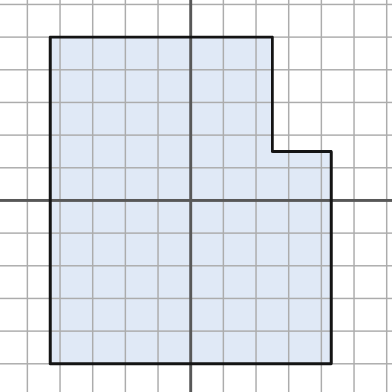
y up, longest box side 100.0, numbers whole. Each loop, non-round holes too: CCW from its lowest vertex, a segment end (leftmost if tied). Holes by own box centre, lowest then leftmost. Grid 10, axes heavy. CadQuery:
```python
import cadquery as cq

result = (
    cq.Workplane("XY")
    .moveTo(-43.0, -50.0)
    .lineTo(43.0, -50.0)
    .lineTo(43.0, 15.0)
    .lineTo(25.0, 15.0)
    .lineTo(25.0, 50.0)
    .lineTo(-43.0, 50.0)
    .close()
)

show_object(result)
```